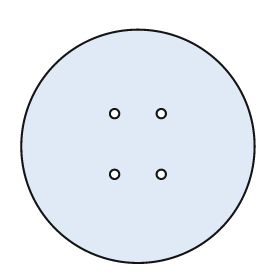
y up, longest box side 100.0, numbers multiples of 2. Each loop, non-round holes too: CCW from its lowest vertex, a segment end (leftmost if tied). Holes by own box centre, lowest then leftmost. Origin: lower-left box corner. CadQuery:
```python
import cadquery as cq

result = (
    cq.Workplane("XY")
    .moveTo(50.0, 50.0)
    .circle(50.0)
    .moveTo(40.0, 38.0)
    .circle(2.0)
    .moveTo(60.0, 38.0)
    .circle(2.0)
    .moveTo(40.0, 64.0)
    .circle(2.0)
    .moveTo(60.0, 64.0)
    .circle(2.0)
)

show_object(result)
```